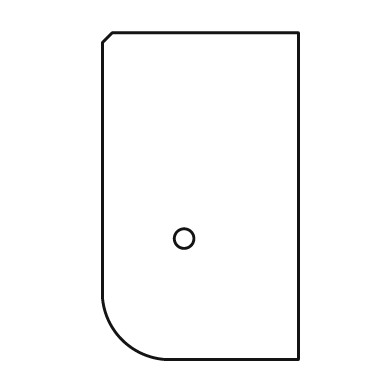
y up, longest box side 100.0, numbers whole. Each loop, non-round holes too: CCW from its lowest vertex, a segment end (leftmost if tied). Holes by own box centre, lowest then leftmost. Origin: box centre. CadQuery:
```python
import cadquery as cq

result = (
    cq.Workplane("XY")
    .moveTo(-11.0, -50.0)
    .lineTo(30.0, -50.0)
    .lineTo(30.0, 50.0)
    .lineTo(-27.0, 50.0)
    .lineTo(-30.0, 47.0)
    .lineTo(-30.0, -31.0)
    .threePointArc((-24.0, -44.0), (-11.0, -50.0))
    .close()
    .moveTo(-5.0, -13.0)
    .circle(3.0)
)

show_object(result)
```